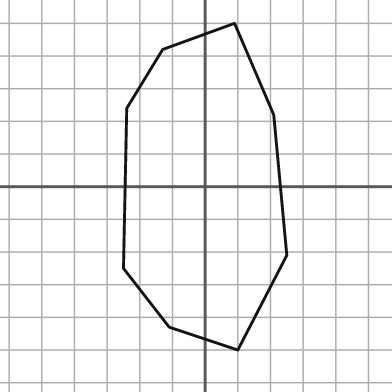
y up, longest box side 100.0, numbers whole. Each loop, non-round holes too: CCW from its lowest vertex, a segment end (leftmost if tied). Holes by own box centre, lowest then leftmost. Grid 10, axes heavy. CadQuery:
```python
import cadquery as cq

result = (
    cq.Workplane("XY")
    .moveTo(10.0, -50.0)
    .lineTo(25.0, -21.0)
    .lineTo(21.0, 22.0)
    .lineTo(9.0, 50.0)
    .lineTo(-13.0, 42.0)
    .lineTo(-24.0, 24.0)
    .lineTo(-25.0, -25.0)
    .lineTo(-11.0, -43.0)
    .close()
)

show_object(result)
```